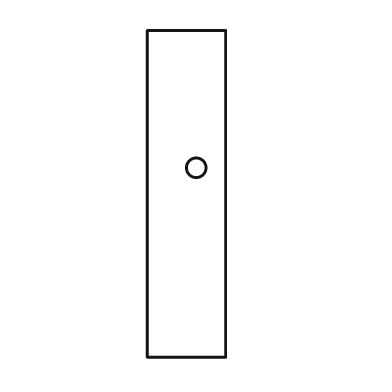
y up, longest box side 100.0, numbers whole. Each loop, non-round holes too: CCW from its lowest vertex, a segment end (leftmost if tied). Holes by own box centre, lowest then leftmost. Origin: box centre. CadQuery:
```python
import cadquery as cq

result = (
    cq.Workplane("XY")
    .moveTo(-12.0, -50.0)
    .lineTo(12.0, -50.0)
    .lineTo(12.0, 50.0)
    .lineTo(-12.0, 50.0)
    .close()
    .moveTo(3.0, 8.0)
    .circle(3.0)
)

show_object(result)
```